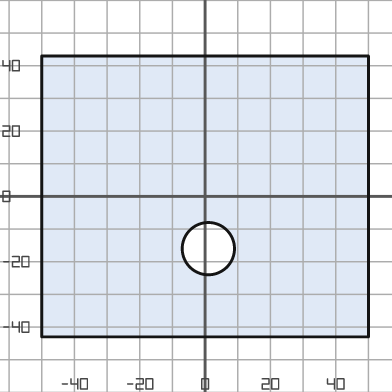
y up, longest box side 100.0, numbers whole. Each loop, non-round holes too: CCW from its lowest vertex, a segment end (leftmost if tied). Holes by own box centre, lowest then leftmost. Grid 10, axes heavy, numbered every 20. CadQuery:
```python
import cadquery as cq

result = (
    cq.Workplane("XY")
    .moveTo(-50.0, -43.0)
    .lineTo(50.0, -43.0)
    .lineTo(50.0, 43.0)
    .lineTo(-50.0, 43.0)
    .close()
    .moveTo(1.0, -16.0)
    .circle(8.0)
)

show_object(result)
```